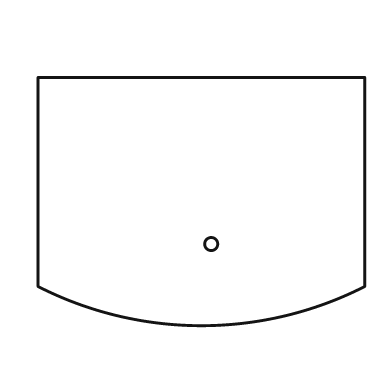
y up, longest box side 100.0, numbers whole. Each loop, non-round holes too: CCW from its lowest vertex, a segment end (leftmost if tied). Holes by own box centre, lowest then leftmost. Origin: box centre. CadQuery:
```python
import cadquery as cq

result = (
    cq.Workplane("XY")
    .moveTo(-50.0, -26.0)
    .threePointArc((0.0, -38.0), (50.0, -26.0))
    .lineTo(50.0, 38.0)
    .lineTo(-50.0, 38.0)
    .close()
    .moveTo(3.0, -13.0)
    .circle(2.0)
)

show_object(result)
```